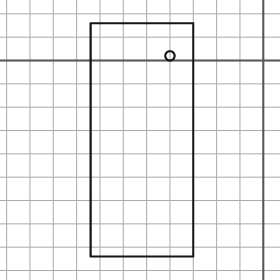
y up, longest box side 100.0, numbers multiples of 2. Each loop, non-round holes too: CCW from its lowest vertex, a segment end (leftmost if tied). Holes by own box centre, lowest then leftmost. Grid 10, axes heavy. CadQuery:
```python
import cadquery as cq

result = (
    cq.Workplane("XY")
    .moveTo(-74.0, -84.0)
    .lineTo(-30.0, -84.0)
    .lineTo(-30.0, 16.0)
    .lineTo(-74.0, 16.0)
    .close()
    .moveTo(-40.0, 2.0)
    .circle(2.0)
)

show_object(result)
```